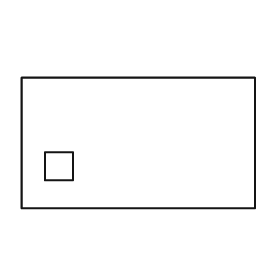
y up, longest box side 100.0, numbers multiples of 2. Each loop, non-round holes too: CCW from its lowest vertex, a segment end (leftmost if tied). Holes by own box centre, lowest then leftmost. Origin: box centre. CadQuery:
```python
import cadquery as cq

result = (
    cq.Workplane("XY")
    .moveTo(-50.0, -28.0)
    .lineTo(50.0, -28.0)
    .lineTo(50.0, 28.0)
    .lineTo(-50.0, 28.0)
    .close()
    .moveTo(-40.0, -16.0)
    .lineTo(-28.0, -16.0)
    .lineTo(-28.0, -4.0)
    .lineTo(-40.0, -4.0)
    .close()
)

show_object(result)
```